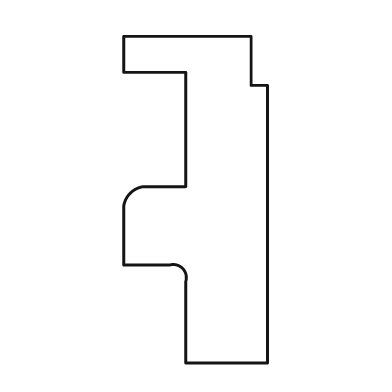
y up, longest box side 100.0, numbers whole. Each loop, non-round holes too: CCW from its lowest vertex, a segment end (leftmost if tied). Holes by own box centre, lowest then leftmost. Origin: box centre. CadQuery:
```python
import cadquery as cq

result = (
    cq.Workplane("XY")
    .moveTo(-3.0, -50.0)
    .lineTo(22.0, -50.0)
    .lineTo(22.0, 35.0)
    .lineTo(17.0, 35.0)
    .lineTo(17.0, 50.0)
    .lineTo(-22.0, 50.0)
    .lineTo(-22.0, 39.0)
    .lineTo(-3.0, 39.0)
    .lineTo(-3.0, 4.0)
    .lineTo(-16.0, 4.0)
    .threePointArc((-20.0, 2.0), (-22.0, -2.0))
    .lineTo(-22.0, -20.0)
    .lineTo(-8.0, -20.0)
    .threePointArc((-4.0, -21.0), (-3.0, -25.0))
    .close()
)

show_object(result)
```